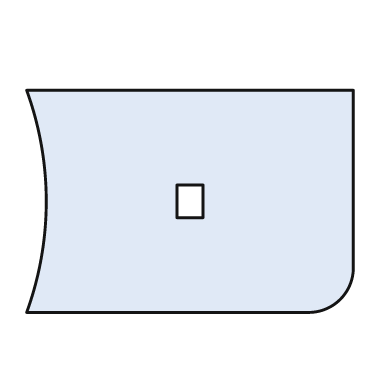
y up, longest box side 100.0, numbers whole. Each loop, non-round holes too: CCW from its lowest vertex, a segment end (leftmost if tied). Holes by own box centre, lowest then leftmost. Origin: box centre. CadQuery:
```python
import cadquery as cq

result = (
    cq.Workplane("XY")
    .moveTo(-50.0, -34.0)
    .lineTo(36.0, -34.0)
    .threePointArc((46.0, -30.0), (50.0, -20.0))
    .lineTo(50.0, 34.0)
    .lineTo(-50.0, 34.0)
    .threePointArc((-44.0, 0.0), (-50.0, -34.0))
    .close()
    .moveTo(-4.0, -5.0)
    .lineTo(4.0, -5.0)
    .lineTo(4.0, 5.0)
    .lineTo(-4.0, 5.0)
    .close()
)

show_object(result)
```